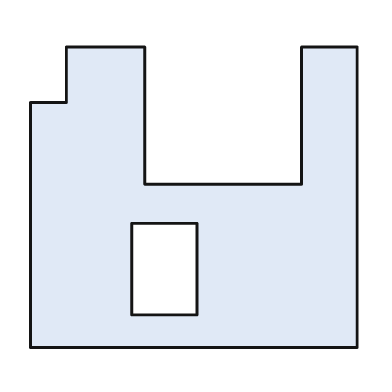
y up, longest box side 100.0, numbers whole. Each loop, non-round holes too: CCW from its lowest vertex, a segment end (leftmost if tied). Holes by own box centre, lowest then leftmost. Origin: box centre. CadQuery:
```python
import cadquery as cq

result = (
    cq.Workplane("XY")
    .moveTo(-50.0, -46.0)
    .lineTo(50.0, -46.0)
    .lineTo(50.0, 46.0)
    .lineTo(33.0, 46.0)
    .lineTo(33.0, 4.0)
    .lineTo(-15.0, 4.0)
    .lineTo(-15.0, 46.0)
    .lineTo(-39.0, 46.0)
    .lineTo(-39.0, 29.0)
    .lineTo(-50.0, 29.0)
    .close()
    .moveTo(-19.0, -36.0)
    .lineTo(1.0, -36.0)
    .lineTo(1.0, -8.0)
    .lineTo(-19.0, -8.0)
    .close()
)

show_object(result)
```